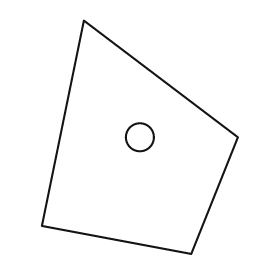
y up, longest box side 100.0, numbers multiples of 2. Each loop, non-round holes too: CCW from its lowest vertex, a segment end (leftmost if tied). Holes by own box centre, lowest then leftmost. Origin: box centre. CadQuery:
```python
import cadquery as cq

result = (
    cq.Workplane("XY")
    .moveTo(22.0, -50.0)
    .lineTo(42.0, 0.0)
    .lineTo(-24.0, 50.0)
    .lineTo(-42.0, -38.0)
    .close()
    .moveTo(0.0, 0.0)
    .circle(6.0)
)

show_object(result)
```